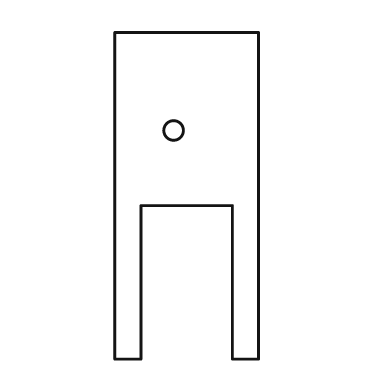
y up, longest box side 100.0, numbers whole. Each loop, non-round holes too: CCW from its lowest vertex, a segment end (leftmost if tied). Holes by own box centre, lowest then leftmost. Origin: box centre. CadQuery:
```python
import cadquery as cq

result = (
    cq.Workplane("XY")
    .moveTo(-22.0, -50.0)
    .lineTo(-14.0, -50.0)
    .lineTo(-14.0, -3.0)
    .lineTo(14.0, -3.0)
    .lineTo(14.0, -50.0)
    .lineTo(22.0, -50.0)
    .lineTo(22.0, 50.0)
    .lineTo(-22.0, 50.0)
    .close()
    .moveTo(-4.0, 20.0)
    .circle(3.0)
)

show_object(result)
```